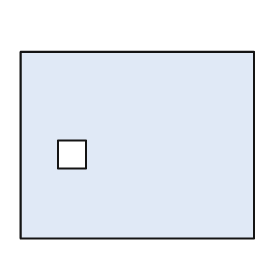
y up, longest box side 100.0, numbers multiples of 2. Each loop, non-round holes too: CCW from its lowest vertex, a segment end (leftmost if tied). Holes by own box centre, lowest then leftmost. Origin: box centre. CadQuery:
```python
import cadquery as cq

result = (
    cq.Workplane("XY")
    .moveTo(-50.0, -40.0)
    .lineTo(50.0, -40.0)
    .lineTo(50.0, 40.0)
    .lineTo(-50.0, 40.0)
    .close()
    .moveTo(-34.0, -10.0)
    .lineTo(-22.0, -10.0)
    .lineTo(-22.0, 2.0)
    .lineTo(-34.0, 2.0)
    .close()
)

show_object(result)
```